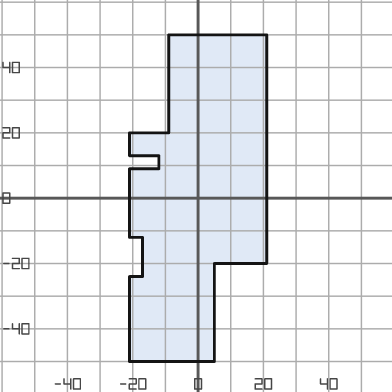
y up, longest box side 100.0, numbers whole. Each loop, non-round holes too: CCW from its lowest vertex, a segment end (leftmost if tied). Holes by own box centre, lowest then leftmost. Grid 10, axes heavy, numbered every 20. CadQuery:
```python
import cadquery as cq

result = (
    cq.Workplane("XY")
    .moveTo(-21.0, -50.0)
    .lineTo(5.0, -50.0)
    .lineTo(5.0, -20.0)
    .lineTo(21.0, -20.0)
    .lineTo(21.0, 50.0)
    .lineTo(-9.0, 50.0)
    .lineTo(-9.0, 20.0)
    .lineTo(-21.0, 20.0)
    .lineTo(-21.0, 13.0)
    .lineTo(-12.0, 13.0)
    .lineTo(-12.0, 9.0)
    .lineTo(-21.0, 9.0)
    .lineTo(-21.0, -12.0)
    .lineTo(-17.0, -12.0)
    .lineTo(-17.0, -24.0)
    .lineTo(-21.0, -24.0)
    .close()
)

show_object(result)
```